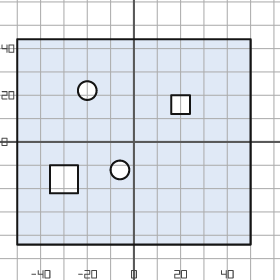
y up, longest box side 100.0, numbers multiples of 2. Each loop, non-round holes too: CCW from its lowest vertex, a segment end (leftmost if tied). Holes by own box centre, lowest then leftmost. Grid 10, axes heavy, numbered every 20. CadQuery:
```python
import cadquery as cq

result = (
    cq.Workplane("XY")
    .moveTo(-50.0, -44.0)
    .lineTo(50.0, -44.0)
    .lineTo(50.0, 44.0)
    .lineTo(-50.0, 44.0)
    .close()
    .moveTo(-36.0, -22.0)
    .lineTo(-24.0, -22.0)
    .lineTo(-24.0, -10.0)
    .lineTo(-36.0, -10.0)
    .close()
    .moveTo(-6.0, -12.0)
    .circle(4.0)
    .moveTo(16.0, 12.0)
    .lineTo(24.0, 12.0)
    .lineTo(24.0, 20.0)
    .lineTo(16.0, 20.0)
    .close()
    .moveTo(-20.0, 22.0)
    .circle(4.0)
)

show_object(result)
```